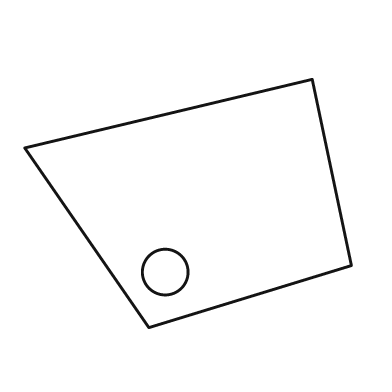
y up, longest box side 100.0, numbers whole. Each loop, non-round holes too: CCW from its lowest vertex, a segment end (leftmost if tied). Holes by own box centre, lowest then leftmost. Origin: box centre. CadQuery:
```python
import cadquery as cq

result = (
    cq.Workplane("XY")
    .moveTo(-12.0, -38.0)
    .lineTo(50.0, -19.0)
    .lineTo(38.0, 38.0)
    .lineTo(-50.0, 17.0)
    .close()
    .moveTo(-7.0, -21.0)
    .circle(7.0)
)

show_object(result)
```